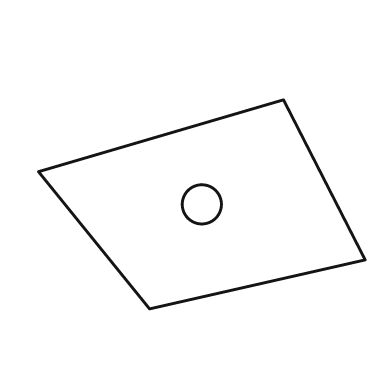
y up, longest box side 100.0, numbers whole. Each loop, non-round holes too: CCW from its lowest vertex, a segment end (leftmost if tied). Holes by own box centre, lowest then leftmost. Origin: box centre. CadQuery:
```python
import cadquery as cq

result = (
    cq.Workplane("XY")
    .moveTo(-16.0, -32.0)
    .lineTo(50.0, -17.0)
    .lineTo(25.0, 32.0)
    .lineTo(-50.0, 10.0)
    .close()
    .moveTo(0.0, 0.0)
    .circle(6.0)
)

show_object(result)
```